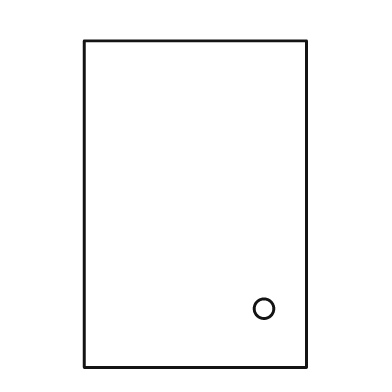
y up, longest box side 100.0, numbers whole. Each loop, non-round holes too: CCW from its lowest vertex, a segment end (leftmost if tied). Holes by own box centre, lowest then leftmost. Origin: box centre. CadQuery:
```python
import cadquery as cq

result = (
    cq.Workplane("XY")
    .moveTo(-34.0, -50.0)
    .lineTo(34.0, -50.0)
    .lineTo(34.0, 50.0)
    .lineTo(-34.0, 50.0)
    .close()
    .moveTo(21.0, -32.0)
    .circle(3.0)
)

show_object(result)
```